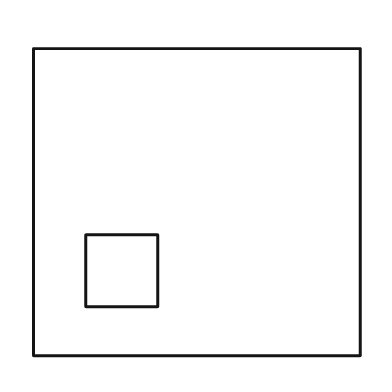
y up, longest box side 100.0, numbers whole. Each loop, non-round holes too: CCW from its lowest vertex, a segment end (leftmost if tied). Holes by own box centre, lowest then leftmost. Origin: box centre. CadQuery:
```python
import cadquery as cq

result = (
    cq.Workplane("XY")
    .moveTo(-50.0, -47.0)
    .lineTo(50.0, -47.0)
    .lineTo(50.0, 47.0)
    .lineTo(-50.0, 47.0)
    .close()
    .moveTo(-34.0, -32.0)
    .lineTo(-12.0, -32.0)
    .lineTo(-12.0, -10.0)
    .lineTo(-34.0, -10.0)
    .close()
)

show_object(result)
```